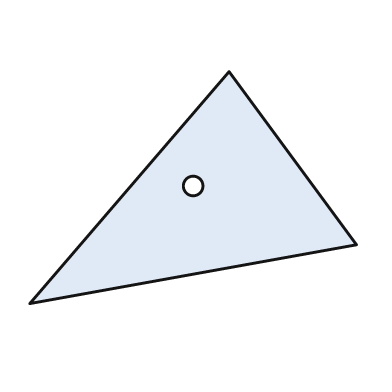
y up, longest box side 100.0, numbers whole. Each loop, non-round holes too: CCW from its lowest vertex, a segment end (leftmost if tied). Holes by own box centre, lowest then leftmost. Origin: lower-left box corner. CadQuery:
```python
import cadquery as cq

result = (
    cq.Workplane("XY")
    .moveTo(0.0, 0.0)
    .lineTo(100.0, 18.0)
    .lineTo(61.0, 71.0)
    .close()
    .moveTo(50.0, 36.0)
    .circle(3.0)
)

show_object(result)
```